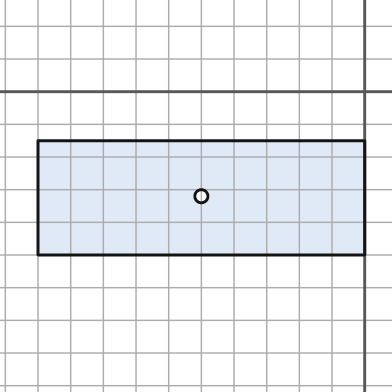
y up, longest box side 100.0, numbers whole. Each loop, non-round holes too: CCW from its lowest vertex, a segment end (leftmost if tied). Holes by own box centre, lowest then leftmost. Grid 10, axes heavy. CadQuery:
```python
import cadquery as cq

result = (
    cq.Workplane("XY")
    .moveTo(-100.0, -50.0)
    .lineTo(0.0, -50.0)
    .lineTo(0.0, -15.0)
    .lineTo(-100.0, -15.0)
    .close()
    .moveTo(-50.0, -32.0)
    .circle(2.0)
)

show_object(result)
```